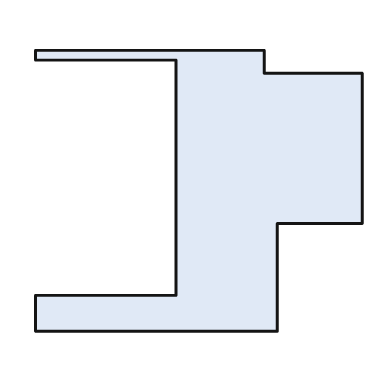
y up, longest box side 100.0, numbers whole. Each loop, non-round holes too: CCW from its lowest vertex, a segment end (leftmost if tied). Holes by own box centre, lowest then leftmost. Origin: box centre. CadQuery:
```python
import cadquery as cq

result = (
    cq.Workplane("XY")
    .moveTo(-50.0, -43.0)
    .lineTo(24.0, -43.0)
    .lineTo(24.0, -10.0)
    .lineTo(50.0, -10.0)
    .lineTo(50.0, 36.0)
    .lineTo(20.0, 36.0)
    .lineTo(20.0, 43.0)
    .lineTo(-50.0, 43.0)
    .lineTo(-50.0, 40.0)
    .lineTo(-7.0, 40.0)
    .lineTo(-7.0, -32.0)
    .lineTo(-50.0, -32.0)
    .close()
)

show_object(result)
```